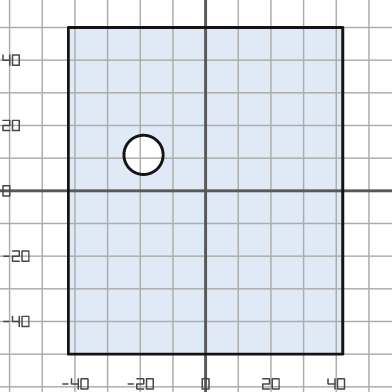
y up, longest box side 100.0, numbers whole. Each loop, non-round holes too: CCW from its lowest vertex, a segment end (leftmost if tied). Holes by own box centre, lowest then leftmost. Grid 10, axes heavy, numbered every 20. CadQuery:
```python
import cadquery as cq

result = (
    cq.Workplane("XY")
    .moveTo(-42.0, -50.0)
    .lineTo(42.0, -50.0)
    .lineTo(42.0, 50.0)
    .lineTo(-42.0, 50.0)
    .close()
    .moveTo(-19.0, 11.0)
    .circle(6.0)
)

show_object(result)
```